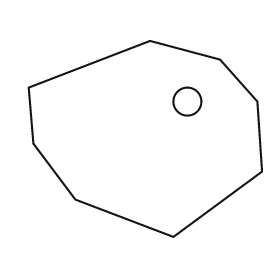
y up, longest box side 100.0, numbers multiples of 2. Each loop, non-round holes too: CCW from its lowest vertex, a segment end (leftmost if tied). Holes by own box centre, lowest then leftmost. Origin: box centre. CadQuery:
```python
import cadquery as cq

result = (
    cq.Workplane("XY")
    .moveTo(12.0, -42.0)
    .lineTo(50.0, -14.0)
    .lineTo(48.0, 16.0)
    .lineTo(32.0, 34.0)
    .lineTo(2.0, 42.0)
    .lineTo(-50.0, 22.0)
    .lineTo(-48.0, -2.0)
    .lineTo(-30.0, -26.0)
    .close()
    .moveTo(18.0, 16.0)
    .circle(6.0)
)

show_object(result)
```